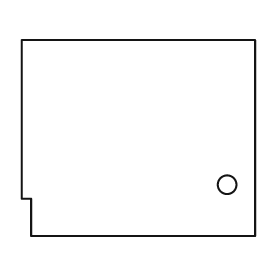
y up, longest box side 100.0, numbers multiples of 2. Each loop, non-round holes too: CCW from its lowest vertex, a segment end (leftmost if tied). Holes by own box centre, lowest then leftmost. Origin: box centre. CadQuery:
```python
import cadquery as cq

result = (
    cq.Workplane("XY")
    .moveTo(-46.0, -42.0)
    .lineTo(50.0, -42.0)
    .lineTo(50.0, 42.0)
    .lineTo(-50.0, 42.0)
    .lineTo(-50.0, -26.0)
    .lineTo(-46.0, -26.0)
    .close()
    .moveTo(38.0, -20.0)
    .circle(4.0)
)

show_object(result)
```